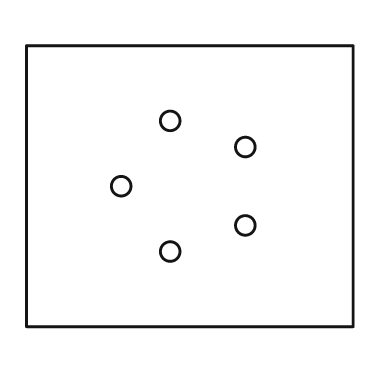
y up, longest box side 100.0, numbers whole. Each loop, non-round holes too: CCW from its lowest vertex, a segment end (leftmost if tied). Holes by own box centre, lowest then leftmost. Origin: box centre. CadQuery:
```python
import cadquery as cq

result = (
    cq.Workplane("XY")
    .moveTo(-50.0, -43.0)
    .lineTo(50.0, -43.0)
    .lineTo(50.0, 43.0)
    .lineTo(-50.0, 43.0)
    .close()
    .moveTo(-6.0, -20.0)
    .circle(3.0)
    .moveTo(17.0, -12.0)
    .circle(3.0)
    .moveTo(-21.0, 0.0)
    .circle(3.0)
    .moveTo(17.0, 12.0)
    .circle(3.0)
    .moveTo(-6.0, 20.0)
    .circle(3.0)
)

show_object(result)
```